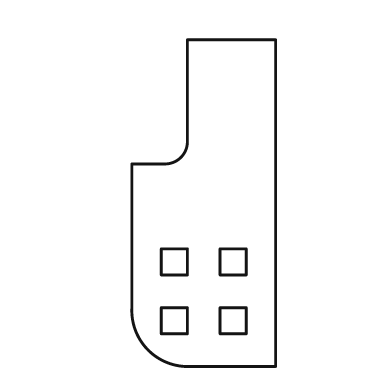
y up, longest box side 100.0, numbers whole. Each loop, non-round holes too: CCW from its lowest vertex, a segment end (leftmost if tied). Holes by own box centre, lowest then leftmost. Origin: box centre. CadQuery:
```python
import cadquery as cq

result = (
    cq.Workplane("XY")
    .moveTo(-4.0, -50.0)
    .lineTo(22.0, -50.0)
    .lineTo(22.0, 50.0)
    .lineTo(-5.0, 50.0)
    .lineTo(-5.0, 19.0)
    .threePointArc((-7.0, 14.0), (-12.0, 12.0))
    .lineTo(-22.0, 12.0)
    .lineTo(-22.0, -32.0)
    .threePointArc((-17.0, -45.0), (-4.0, -50.0))
    .close()
    .moveTo(-13.0, -40.0)
    .lineTo(-5.0, -40.0)
    .lineTo(-5.0, -32.0)
    .lineTo(-13.0, -32.0)
    .close()
    .moveTo(5.0, -40.0)
    .lineTo(13.0, -40.0)
    .lineTo(13.0, -32.0)
    .lineTo(5.0, -32.0)
    .close()
    .moveTo(-13.0, -22.0)
    .lineTo(-5.0, -22.0)
    .lineTo(-5.0, -14.0)
    .lineTo(-13.0, -14.0)
    .close()
    .moveTo(5.0, -22.0)
    .lineTo(13.0, -22.0)
    .lineTo(13.0, -14.0)
    .lineTo(5.0, -14.0)
    .close()
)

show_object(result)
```